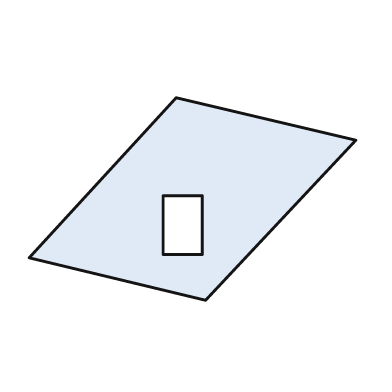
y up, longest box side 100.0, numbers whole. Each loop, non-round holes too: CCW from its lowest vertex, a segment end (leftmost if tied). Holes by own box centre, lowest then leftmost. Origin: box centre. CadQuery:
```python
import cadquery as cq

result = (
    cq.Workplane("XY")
    .moveTo(4.0, -31.0)
    .lineTo(50.0, 18.0)
    .lineTo(-5.0, 31.0)
    .lineTo(-50.0, -18.0)
    .close()
    .moveTo(-9.0, -17.0)
    .lineTo(3.0, -17.0)
    .lineTo(3.0, 1.0)
    .lineTo(-9.0, 1.0)
    .close()
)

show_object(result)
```